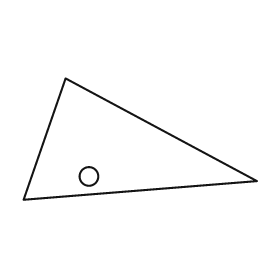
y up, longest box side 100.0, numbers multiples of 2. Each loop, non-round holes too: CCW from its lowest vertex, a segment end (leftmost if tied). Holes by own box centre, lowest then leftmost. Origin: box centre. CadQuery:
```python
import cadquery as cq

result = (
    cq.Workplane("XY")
    .moveTo(-50.0, -26.0)
    .lineTo(50.0, -18.0)
    .lineTo(-32.0, 26.0)
    .close()
    .moveTo(-22.0, -16.0)
    .circle(4.0)
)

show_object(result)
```